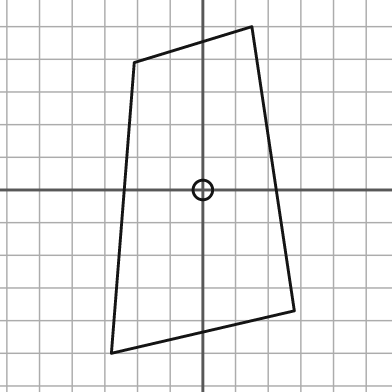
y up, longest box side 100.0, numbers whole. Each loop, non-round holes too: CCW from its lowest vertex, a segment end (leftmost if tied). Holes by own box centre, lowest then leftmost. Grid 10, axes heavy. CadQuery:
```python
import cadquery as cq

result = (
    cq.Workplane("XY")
    .moveTo(-28.0, -50.0)
    .lineTo(28.0, -37.0)
    .lineTo(15.0, 50.0)
    .lineTo(-21.0, 39.0)
    .close()
    .moveTo(0.0, 0.0)
    .circle(3.0)
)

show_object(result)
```